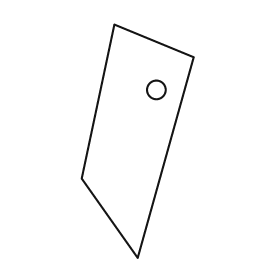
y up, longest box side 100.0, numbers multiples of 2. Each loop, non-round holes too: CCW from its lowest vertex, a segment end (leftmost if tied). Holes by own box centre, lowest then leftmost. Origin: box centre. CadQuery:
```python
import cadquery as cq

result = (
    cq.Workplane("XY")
    .moveTo(0.0, -50.0)
    .lineTo(24.0, 36.0)
    .lineTo(-10.0, 50.0)
    .lineTo(-24.0, -16.0)
    .close()
    .moveTo(8.0, 22.0)
    .circle(4.0)
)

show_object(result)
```